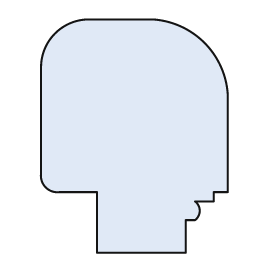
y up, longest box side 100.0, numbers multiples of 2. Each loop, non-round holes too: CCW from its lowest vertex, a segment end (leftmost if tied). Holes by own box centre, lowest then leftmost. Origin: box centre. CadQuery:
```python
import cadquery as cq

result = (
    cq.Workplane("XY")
    .moveTo(-16.0, -50.0)
    .lineTo(22.0, -50.0)
    .lineTo(22.0, -36.0)
    .lineTo(26.0, -36.0)
    .threePointArc((28.0, -32.0), (26.0, -28.0))
    .lineTo(34.0, -28.0)
    .lineTo(34.0, -24.0)
    .lineTo(40.0, -24.0)
    .lineTo(40.0, 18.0)
    .threePointArc((30.0, 40.0), (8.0, 50.0))
    .lineTo(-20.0, 50.0)
    .threePointArc((-34.0, 44.0), (-40.0, 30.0))
    .lineTo(-40.0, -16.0)
    .threePointArc((-38.0, -22.0), (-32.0, -24.0))
    .lineTo(-16.0, -24.0)
    .close()
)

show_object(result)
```